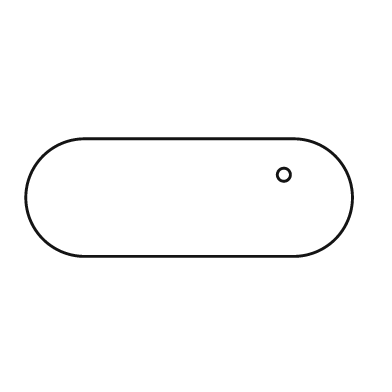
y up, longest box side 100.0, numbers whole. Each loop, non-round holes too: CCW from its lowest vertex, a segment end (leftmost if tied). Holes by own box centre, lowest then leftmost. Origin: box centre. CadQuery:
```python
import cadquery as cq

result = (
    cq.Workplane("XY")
    .moveTo(-32.0, -18.0)
    .lineTo(32.0, -18.0)
    .threePointArc((50.0, 0.0), (32.0, 18.0))
    .lineTo(-32.0, 18.0)
    .threePointArc((-50.0, 0.0), (-32.0, -18.0))
    .close()
    .moveTo(29.0, 7.0)
    .circle(2.0)
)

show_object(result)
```